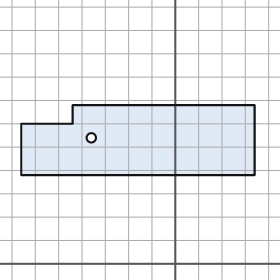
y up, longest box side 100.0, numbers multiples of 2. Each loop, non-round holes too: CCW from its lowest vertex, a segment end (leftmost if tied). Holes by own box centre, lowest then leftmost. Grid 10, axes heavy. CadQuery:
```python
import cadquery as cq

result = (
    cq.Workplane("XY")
    .moveTo(-66.0, 38.0)
    .lineTo(34.0, 38.0)
    .lineTo(34.0, 68.0)
    .lineTo(-44.0, 68.0)
    .lineTo(-44.0, 60.0)
    .lineTo(-66.0, 60.0)
    .close()
    .moveTo(-36.0, 54.0)
    .circle(2.0)
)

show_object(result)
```